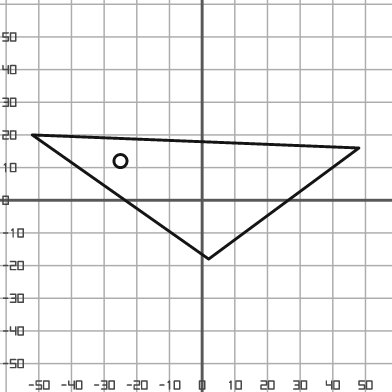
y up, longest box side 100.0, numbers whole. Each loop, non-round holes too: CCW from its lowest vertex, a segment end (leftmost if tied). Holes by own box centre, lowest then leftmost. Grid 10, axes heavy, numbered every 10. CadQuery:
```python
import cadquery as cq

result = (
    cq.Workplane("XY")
    .moveTo(2.0, -18.0)
    .lineTo(48.0, 16.0)
    .lineTo(-52.0, 20.0)
    .close()
    .moveTo(-25.0, 12.0)
    .circle(2.0)
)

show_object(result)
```